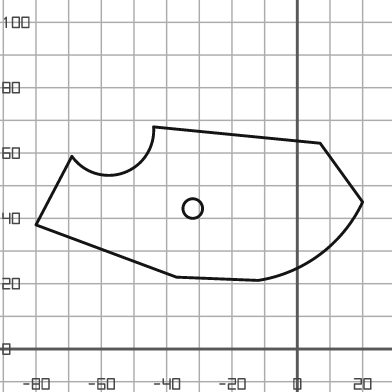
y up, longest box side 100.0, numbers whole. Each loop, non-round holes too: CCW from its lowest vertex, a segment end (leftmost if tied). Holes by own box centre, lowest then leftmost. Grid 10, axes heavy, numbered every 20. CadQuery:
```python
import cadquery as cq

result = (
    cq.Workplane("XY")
    .moveTo(-12.0, 21.0)
    .threePointArc((7.0, 29.0), (20.0, 45.0))
    .lineTo(7.0, 63.0)
    .lineTo(-44.0, 68.0)
    .threePointArc((-53.0, 54.0), (-69.0, 59.0))
    .lineTo(-80.0, 38.0)
    .lineTo(-37.0, 22.0)
    .close()
    .moveTo(-32.0, 43.0)
    .circle(3.0)
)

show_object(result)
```